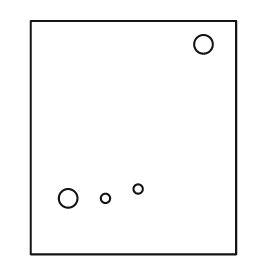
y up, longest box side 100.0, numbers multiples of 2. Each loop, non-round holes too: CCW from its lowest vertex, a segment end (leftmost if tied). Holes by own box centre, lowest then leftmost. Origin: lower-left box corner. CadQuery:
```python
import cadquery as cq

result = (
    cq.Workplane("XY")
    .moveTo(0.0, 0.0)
    .lineTo(88.0, 0.0)
    .lineTo(88.0, 100.0)
    .lineTo(0.0, 100.0)
    .close()
    .moveTo(16.0, 24.0)
    .circle(4.0)
    .moveTo(32.0, 24.0)
    .circle(2.0)
    .moveTo(46.0, 28.0)
    .circle(2.0)
    .moveTo(74.0, 90.0)
    .circle(4.0)
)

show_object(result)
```